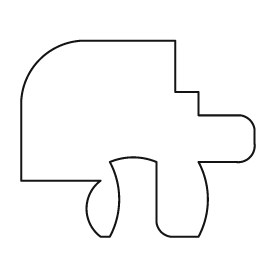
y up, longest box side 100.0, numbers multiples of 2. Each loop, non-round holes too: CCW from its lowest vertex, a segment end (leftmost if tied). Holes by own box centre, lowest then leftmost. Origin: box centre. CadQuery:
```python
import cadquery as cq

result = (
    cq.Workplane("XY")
    .moveTo(-16.0, -42.0)
    .lineTo(-12.0, -42.0)
    .threePointArc((-8.0, -26.0), (-12.0, -10.0))
    .threePointArc((-2.0, -8.0), (8.0, -10.0))
    .lineTo(8.0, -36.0)
    .threePointArc((10.0, -40.0), (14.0, -42.0))
    .lineTo(26.0, -42.0)
    .threePointArc((30.0, -26.0), (26.0, -10.0))
    .lineTo(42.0, -10.0)
    .threePointArc((48.0, -8.0), (50.0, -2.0))
    .lineTo(50.0, 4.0)
    .threePointArc((48.0, 8.0), (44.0, 10.0))
    .lineTo(26.0, 10.0)
    .lineTo(26.0, 20.0)
    .lineTo(16.0, 20.0)
    .lineTo(16.0, 42.0)
    .lineTo(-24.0, 42.0)
    .threePointArc((-42.0, 34.0), (-50.0, 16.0))
    .lineTo(-50.0, -18.0)
    .lineTo(-16.0, -18.0)
    .threePointArc((-22.0, -30.0), (-16.0, -42.0))
    .close()
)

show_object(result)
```